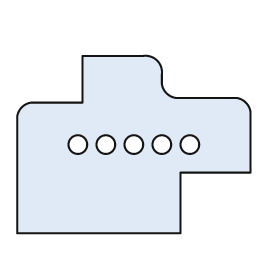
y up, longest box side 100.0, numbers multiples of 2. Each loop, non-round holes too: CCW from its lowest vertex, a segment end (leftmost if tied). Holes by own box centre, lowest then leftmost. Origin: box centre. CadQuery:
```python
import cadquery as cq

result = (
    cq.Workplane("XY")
    .moveTo(-50.0, -38.0)
    .lineTo(20.0, -38.0)
    .lineTo(20.0, -12.0)
    .lineTo(50.0, -12.0)
    .lineTo(50.0, 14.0)
    .threePointArc((48.0, 18.0), (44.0, 20.0))
    .lineTo(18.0, 20.0)
    .threePointArc((14.0, 22.0), (12.0, 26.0))
    .lineTo(12.0, 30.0)
    .threePointArc((10.0, 36.0), (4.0, 38.0))
    .lineTo(-22.0, 38.0)
    .lineTo(-22.0, 18.0)
    .lineTo(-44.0, 18.0)
    .threePointArc((-48.0, 16.0), (-50.0, 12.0))
    .close()
    .moveTo(-24.0, 0.0)
    .circle(4.0)
    .moveTo(-12.0, 0.0)
    .circle(4.0)
    .moveTo(0.0, 0.0)
    .circle(4.0)
    .moveTo(12.0, 0.0)
    .circle(4.0)
    .moveTo(24.0, 0.0)
    .circle(4.0)
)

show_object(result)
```